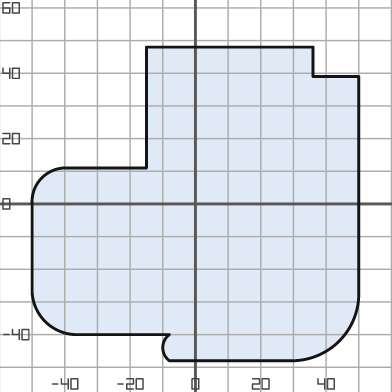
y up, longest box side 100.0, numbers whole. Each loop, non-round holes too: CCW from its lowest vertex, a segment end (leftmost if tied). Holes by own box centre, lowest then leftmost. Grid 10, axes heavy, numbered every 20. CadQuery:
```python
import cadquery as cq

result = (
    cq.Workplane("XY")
    .moveTo(-8.0, -48.0)
    .lineTo(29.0, -48.0)
    .threePointArc((44.0, -42.0), (50.0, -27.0))
    .lineTo(50.0, 39.0)
    .lineTo(36.0, 39.0)
    .lineTo(36.0, 48.0)
    .lineTo(-15.0, 48.0)
    .lineTo(-15.0, 11.0)
    .lineTo(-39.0, 11.0)
    .threePointArc((-47.0, 8.0), (-50.0, 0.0))
    .lineTo(-50.0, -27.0)
    .threePointArc((-46.0, -36.0), (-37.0, -40.0))
    .lineTo(-8.0, -40.0)
    .threePointArc((-10.0, -44.0), (-8.0, -48.0))
    .close()
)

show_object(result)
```